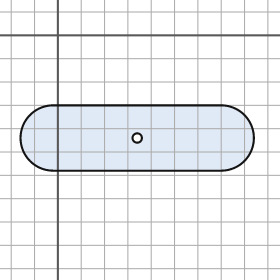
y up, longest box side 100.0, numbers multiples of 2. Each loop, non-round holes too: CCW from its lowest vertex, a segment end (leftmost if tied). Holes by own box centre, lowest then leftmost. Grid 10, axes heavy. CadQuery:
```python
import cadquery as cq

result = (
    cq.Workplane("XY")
    .moveTo(-2.0, -58.0)
    .lineTo(70.0, -58.0)
    .threePointArc((84.0, -44.0), (70.0, -30.0))
    .lineTo(-2.0, -30.0)
    .threePointArc((-16.0, -44.0), (-2.0, -58.0))
    .close()
    .moveTo(34.0, -44.0)
    .circle(2.0)
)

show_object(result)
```